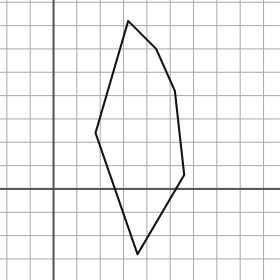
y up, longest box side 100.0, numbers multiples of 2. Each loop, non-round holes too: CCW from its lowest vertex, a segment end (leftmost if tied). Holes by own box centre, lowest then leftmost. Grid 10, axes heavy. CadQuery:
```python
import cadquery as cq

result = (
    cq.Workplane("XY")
    .moveTo(36.0, -28.0)
    .lineTo(56.0, 6.0)
    .lineTo(52.0, 42.0)
    .lineTo(44.0, 60.0)
    .lineTo(32.0, 72.0)
    .lineTo(18.0, 24.0)
    .close()
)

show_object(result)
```